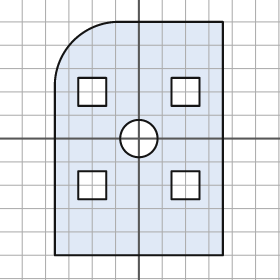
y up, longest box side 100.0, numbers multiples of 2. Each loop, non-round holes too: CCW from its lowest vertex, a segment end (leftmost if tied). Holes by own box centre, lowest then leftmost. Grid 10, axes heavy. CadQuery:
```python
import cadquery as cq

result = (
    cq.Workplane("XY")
    .moveTo(-36.0, -50.0)
    .lineTo(36.0, -50.0)
    .lineTo(36.0, 50.0)
    .lineTo(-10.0, 50.0)
    .threePointArc((-28.0, 42.0), (-36.0, 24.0))
    .close()
    .moveTo(-26.0, -26.0)
    .lineTo(-14.0, -26.0)
    .lineTo(-14.0, -14.0)
    .lineTo(-26.0, -14.0)
    .close()
    .moveTo(14.0, -26.0)
    .lineTo(26.0, -26.0)
    .lineTo(26.0, -14.0)
    .lineTo(14.0, -14.0)
    .close()
    .moveTo(0.0, 0.0)
    .circle(8.0)
    .moveTo(-26.0, 14.0)
    .lineTo(-14.0, 14.0)
    .lineTo(-14.0, 26.0)
    .lineTo(-26.0, 26.0)
    .close()
    .moveTo(14.0, 14.0)
    .lineTo(26.0, 14.0)
    .lineTo(26.0, 26.0)
    .lineTo(14.0, 26.0)
    .close()
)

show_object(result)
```